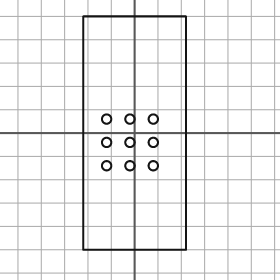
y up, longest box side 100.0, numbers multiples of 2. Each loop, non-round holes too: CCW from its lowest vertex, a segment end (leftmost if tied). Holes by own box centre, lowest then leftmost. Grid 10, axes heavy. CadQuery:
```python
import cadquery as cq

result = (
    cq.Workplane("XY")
    .moveTo(-22.0, -50.0)
    .lineTo(22.0, -50.0)
    .lineTo(22.0, 50.0)
    .lineTo(-22.0, 50.0)
    .close()
    .moveTo(-12.0, -14.0)
    .circle(2.0)
    .moveTo(-2.0, -14.0)
    .circle(2.0)
    .moveTo(8.0, -14.0)
    .circle(2.0)
    .moveTo(-12.0, -4.0)
    .circle(2.0)
    .moveTo(-2.0, -4.0)
    .circle(2.0)
    .moveTo(8.0, -4.0)
    .circle(2.0)
    .moveTo(-12.0, 6.0)
    .circle(2.0)
    .moveTo(-2.0, 6.0)
    .circle(2.0)
    .moveTo(8.0, 6.0)
    .circle(2.0)
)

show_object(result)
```